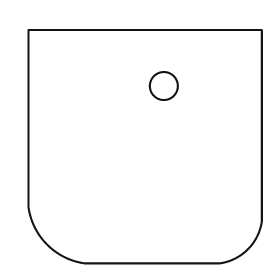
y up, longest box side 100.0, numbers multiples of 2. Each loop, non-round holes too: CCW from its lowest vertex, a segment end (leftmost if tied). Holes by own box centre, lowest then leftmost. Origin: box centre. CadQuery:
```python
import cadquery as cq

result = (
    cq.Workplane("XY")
    .moveTo(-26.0, -50.0)
    .lineTo(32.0, -50.0)
    .threePointArc((44.0, -44.0), (50.0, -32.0))
    .lineTo(50.0, 50.0)
    .lineTo(-50.0, 50.0)
    .lineTo(-50.0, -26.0)
    .threePointArc((-42.0, -42.0), (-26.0, -50.0))
    .close()
    .moveTo(8.0, 26.0)
    .circle(6.0)
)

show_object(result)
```